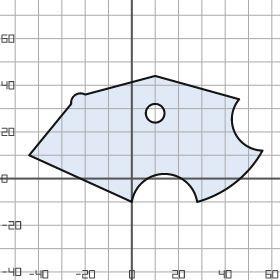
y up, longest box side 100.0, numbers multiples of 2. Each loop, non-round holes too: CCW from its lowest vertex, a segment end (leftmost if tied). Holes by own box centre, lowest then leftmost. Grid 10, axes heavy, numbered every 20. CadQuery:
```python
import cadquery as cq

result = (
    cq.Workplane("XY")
    .moveTo(0.0, -10.0)
    .threePointArc((14.0, 2.0), (28.0, -10.0))
    .threePointArc((44.0, -2.0), (56.0, 12.0))
    .threePointArc((44.0, 20.0), (46.0, 34.0))
    .lineTo(10.0, 44.0)
    .lineTo(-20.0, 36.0)
    .threePointArc((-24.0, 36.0), (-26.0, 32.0))
    .lineTo(-44.0, 10.0)
    .close()
    .moveTo(10.0, 28.0)
    .circle(4.0)
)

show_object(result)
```